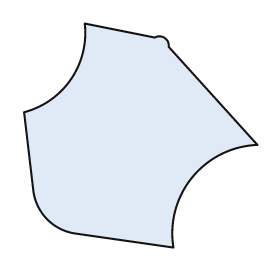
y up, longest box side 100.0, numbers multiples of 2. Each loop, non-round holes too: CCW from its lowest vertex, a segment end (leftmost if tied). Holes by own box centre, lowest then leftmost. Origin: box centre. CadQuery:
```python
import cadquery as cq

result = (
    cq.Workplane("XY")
    .moveTo(14.0, -48.0)
    .threePointArc((22.0, -18.0), (50.0, -4.0))
    .lineTo(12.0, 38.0)
    .threePointArc((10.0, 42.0), (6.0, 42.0))
    .lineTo(-24.0, 48.0)
    .threePointArc((-30.0, 24.0), (-50.0, 10.0))
    .lineTo(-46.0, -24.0)
    .threePointArc((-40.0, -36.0), (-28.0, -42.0))
    .close()
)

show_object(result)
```